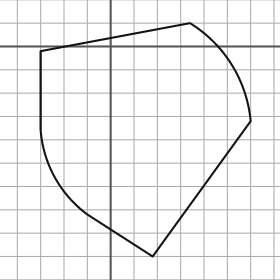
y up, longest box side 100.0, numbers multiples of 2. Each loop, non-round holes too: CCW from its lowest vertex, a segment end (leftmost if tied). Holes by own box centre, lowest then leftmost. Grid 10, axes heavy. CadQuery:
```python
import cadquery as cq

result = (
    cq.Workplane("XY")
    .moveTo(18.0, -90.0)
    .lineTo(60.0, -32.0)
    .threePointArc((52.0, -8.0), (34.0, 10.0))
    .lineTo(-30.0, -2.0)
    .lineTo(-30.0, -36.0)
    .threePointArc((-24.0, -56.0), (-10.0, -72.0))
    .close()
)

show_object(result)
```